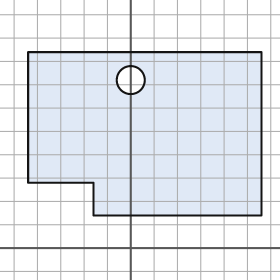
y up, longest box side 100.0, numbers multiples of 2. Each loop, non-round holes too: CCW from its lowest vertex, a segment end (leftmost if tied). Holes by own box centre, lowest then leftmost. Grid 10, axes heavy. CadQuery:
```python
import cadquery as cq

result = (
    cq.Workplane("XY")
    .moveTo(-16.0, 14.0)
    .lineTo(56.0, 14.0)
    .lineTo(56.0, 84.0)
    .lineTo(-44.0, 84.0)
    .lineTo(-44.0, 28.0)
    .lineTo(-16.0, 28.0)
    .close()
    .moveTo(0.0, 72.0)
    .circle(6.0)
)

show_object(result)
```